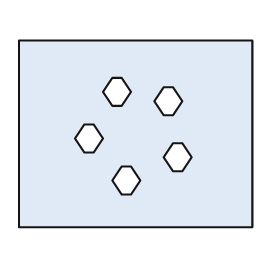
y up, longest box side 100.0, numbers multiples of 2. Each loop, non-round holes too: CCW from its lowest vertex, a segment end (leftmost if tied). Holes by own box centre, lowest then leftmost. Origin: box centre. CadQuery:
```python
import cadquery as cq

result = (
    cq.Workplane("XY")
    .moveTo(-50.0, -40.0)
    .lineTo(50.0, -40.0)
    .lineTo(50.0, 40.0)
    .lineTo(-50.0, 40.0)
    .close()
    .moveTo(-6.0, -26.0)
    .lineTo(-2.0, -26.0)
    .lineTo(2.0, -20.0)
    .lineTo(-2.0, -14.0)
    .lineTo(-6.0, -14.0)
    .lineTo(-10.0, -20.0)
    .close()
    .moveTo(16.0, -16.0)
    .lineTo(20.0, -16.0)
    .lineTo(24.0, -10.0)
    .lineTo(20.0, -4.0)
    .lineTo(16.0, -4.0)
    .lineTo(12.0, -10.0)
    .close()
    .moveTo(-22.0, -8.0)
    .lineTo(-18.0, -8.0)
    .lineTo(-14.0, -2.0)
    .lineTo(-18.0, 4.0)
    .lineTo(-22.0, 4.0)
    .lineTo(-26.0, -2.0)
    .close()
    .moveTo(12.0, 8.0)
    .lineTo(16.0, 8.0)
    .lineTo(20.0, 14.0)
    .lineTo(16.0, 20.0)
    .lineTo(12.0, 20.0)
    .lineTo(8.0, 14.0)
    .close()
    .moveTo(-10.0, 12.0)
    .lineTo(-6.0, 12.0)
    .lineTo(-2.0, 18.0)
    .lineTo(-6.0, 24.0)
    .lineTo(-10.0, 24.0)
    .lineTo(-14.0, 18.0)
    .close()
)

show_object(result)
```